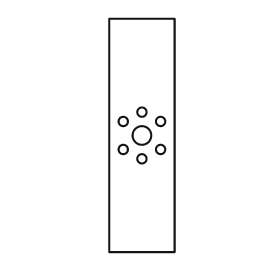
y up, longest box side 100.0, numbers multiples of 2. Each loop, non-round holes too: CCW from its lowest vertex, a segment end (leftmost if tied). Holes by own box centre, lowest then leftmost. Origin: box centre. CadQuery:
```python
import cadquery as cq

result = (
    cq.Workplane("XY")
    .moveTo(-14.0, -50.0)
    .lineTo(14.0, -50.0)
    .lineTo(14.0, 50.0)
    .lineTo(-14.0, 50.0)
    .close()
    .moveTo(0.0, -10.0)
    .circle(2.0)
    .moveTo(-8.0, -6.0)
    .circle(2.0)
    .moveTo(8.0, -6.0)
    .circle(2.0)
    .moveTo(0.0, 0.0)
    .circle(4.0)
    .moveTo(-8.0, 6.0)
    .circle(2.0)
    .moveTo(8.0, 6.0)
    .circle(2.0)
    .moveTo(0.0, 10.0)
    .circle(2.0)
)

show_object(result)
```